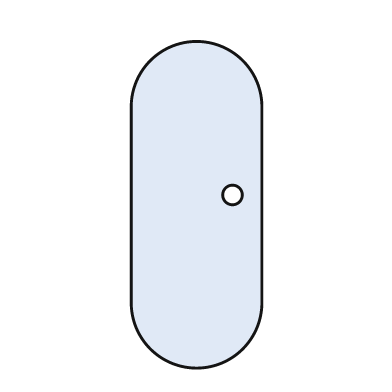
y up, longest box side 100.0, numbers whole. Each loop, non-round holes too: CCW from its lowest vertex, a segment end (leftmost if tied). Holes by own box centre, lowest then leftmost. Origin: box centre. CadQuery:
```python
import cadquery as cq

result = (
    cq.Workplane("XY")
    .moveTo(-20.0, -30.0)
    .threePointArc((0.0, -50.0), (20.0, -30.0))
    .lineTo(20.0, 30.0)
    .threePointArc((0.0, 50.0), (-20.0, 30.0))
    .close()
    .moveTo(11.0, 3.0)
    .circle(3.0)
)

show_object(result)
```